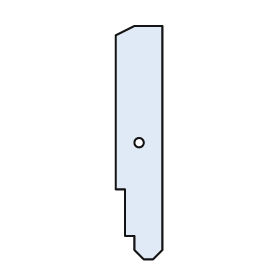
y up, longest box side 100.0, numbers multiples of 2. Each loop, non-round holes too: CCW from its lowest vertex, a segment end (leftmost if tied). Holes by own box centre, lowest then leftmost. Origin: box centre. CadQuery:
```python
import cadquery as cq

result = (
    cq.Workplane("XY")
    .moveTo(2.0, -50.0)
    .lineTo(6.0, -50.0)
    .lineTo(10.0, -46.0)
    .lineTo(10.0, 50.0)
    .lineTo(-2.0, 50.0)
    .lineTo(-10.0, 46.0)
    .lineTo(-10.0, -20.0)
    .lineTo(-6.0, -20.0)
    .lineTo(-6.0, -40.0)
    .lineTo(-2.0, -40.0)
    .lineTo(-2.0, -46.0)
    .close()
    .moveTo(0.0, 0.0)
    .circle(2.0)
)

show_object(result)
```